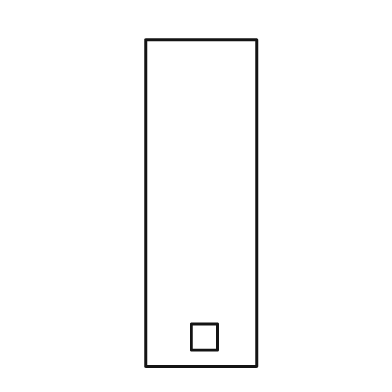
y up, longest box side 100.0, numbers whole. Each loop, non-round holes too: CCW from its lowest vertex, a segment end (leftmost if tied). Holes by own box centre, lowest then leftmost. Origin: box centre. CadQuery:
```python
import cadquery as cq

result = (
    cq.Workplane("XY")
    .moveTo(-17.0, -50.0)
    .lineTo(17.0, -50.0)
    .lineTo(17.0, 50.0)
    .lineTo(-17.0, 50.0)
    .close()
    .moveTo(-3.0, -45.0)
    .lineTo(5.0, -45.0)
    .lineTo(5.0, -37.0)
    .lineTo(-3.0, -37.0)
    .close()
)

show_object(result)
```